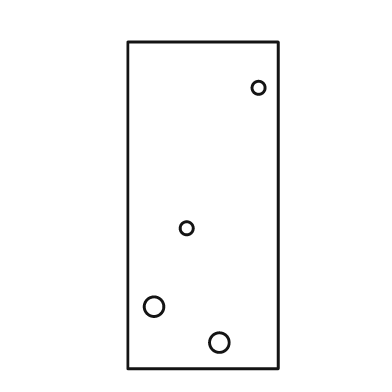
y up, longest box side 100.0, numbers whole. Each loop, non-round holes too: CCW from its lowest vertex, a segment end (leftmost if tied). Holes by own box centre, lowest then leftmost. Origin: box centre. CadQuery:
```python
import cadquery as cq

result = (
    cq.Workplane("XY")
    .moveTo(-23.0, -50.0)
    .lineTo(23.0, -50.0)
    .lineTo(23.0, 50.0)
    .lineTo(-23.0, 50.0)
    .close()
    .moveTo(5.0, -42.0)
    .circle(3.0)
    .moveTo(-15.0, -31.0)
    .circle(3.0)
    .moveTo(-5.0, -7.0)
    .circle(2.0)
    .moveTo(17.0, 36.0)
    .circle(2.0)
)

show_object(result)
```